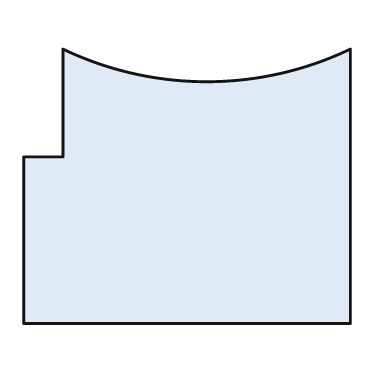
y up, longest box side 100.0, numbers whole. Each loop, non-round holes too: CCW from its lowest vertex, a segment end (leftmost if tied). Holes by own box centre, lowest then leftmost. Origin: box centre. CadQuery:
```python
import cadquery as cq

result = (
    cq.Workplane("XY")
    .moveTo(-50.0, -42.0)
    .lineTo(50.0, -42.0)
    .lineTo(50.0, 42.0)
    .threePointArc((6.0, 32.0), (-38.0, 42.0))
    .lineTo(-38.0, 9.0)
    .lineTo(-50.0, 9.0)
    .close()
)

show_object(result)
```